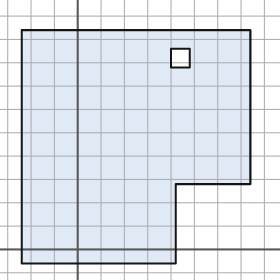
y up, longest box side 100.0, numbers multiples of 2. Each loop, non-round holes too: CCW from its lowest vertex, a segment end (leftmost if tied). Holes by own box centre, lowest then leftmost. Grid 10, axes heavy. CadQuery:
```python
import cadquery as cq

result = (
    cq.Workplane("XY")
    .moveTo(-24.0, -6.0)
    .lineTo(42.0, -6.0)
    .lineTo(42.0, 28.0)
    .lineTo(74.0, 28.0)
    .lineTo(74.0, 94.0)
    .lineTo(-24.0, 94.0)
    .close()
    .moveTo(40.0, 78.0)
    .lineTo(48.0, 78.0)
    .lineTo(48.0, 86.0)
    .lineTo(40.0, 86.0)
    .close()
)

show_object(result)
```